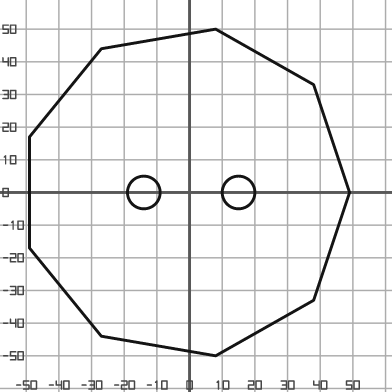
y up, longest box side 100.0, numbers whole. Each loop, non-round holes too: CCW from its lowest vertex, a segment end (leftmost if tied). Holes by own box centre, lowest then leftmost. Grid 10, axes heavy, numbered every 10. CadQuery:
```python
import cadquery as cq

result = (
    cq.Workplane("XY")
    .moveTo(8.0, -50.0)
    .lineTo(38.0, -33.0)
    .lineTo(49.0, 0.0)
    .lineTo(38.0, 33.0)
    .lineTo(8.0, 50.0)
    .lineTo(-27.0, 44.0)
    .lineTo(-49.0, 17.0)
    .lineTo(-49.0, -17.0)
    .lineTo(-27.0, -44.0)
    .close()
    .moveTo(-14.0, 0.0)
    .circle(5.0)
    .moveTo(15.0, 0.0)
    .circle(5.0)
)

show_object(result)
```